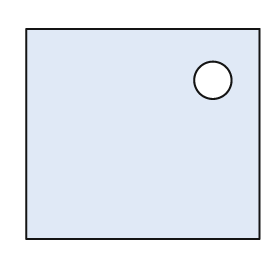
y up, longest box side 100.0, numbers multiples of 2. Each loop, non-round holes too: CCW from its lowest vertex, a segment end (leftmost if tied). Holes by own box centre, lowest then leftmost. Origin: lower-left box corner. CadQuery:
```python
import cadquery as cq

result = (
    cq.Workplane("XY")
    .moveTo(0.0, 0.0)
    .lineTo(100.0, 0.0)
    .lineTo(100.0, 90.0)
    .lineTo(0.0, 90.0)
    .close()
    .moveTo(80.0, 68.0)
    .circle(8.0)
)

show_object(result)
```